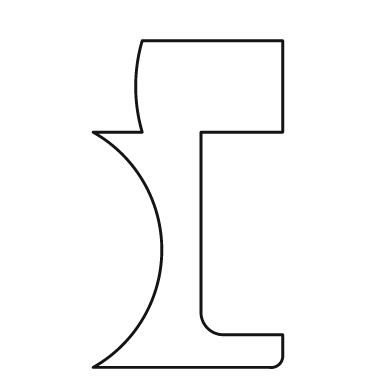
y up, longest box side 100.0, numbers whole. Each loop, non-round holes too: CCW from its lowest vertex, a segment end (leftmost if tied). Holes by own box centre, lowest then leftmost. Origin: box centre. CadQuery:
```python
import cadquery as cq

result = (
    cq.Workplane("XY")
    .moveTo(-29.0, -50.0)
    .lineTo(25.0, -50.0)
    .threePointArc((28.0, -49.0), (29.0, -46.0))
    .lineTo(29.0, -40.0)
    .lineTo(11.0, -40.0)
    .threePointArc((6.0, -38.0), (4.0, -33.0))
    .lineTo(4.0, 22.0)
    .lineTo(29.0, 22.0)
    .lineTo(29.0, 50.0)
    .lineTo(-14.0, 50.0)
    .threePointArc((-16.0, 36.0), (-14.0, 22.0))
    .lineTo(-29.0, 22.0)
    .threePointArc((-8.0, -14.0), (-29.0, -50.0))
    .close()
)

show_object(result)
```